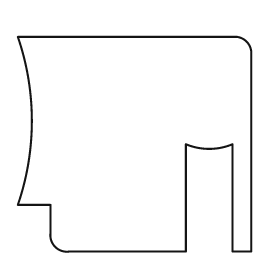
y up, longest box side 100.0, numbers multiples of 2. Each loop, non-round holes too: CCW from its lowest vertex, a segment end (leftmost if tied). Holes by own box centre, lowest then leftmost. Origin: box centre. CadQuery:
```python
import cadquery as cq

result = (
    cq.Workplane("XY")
    .moveTo(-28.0, -46.0)
    .lineTo(22.0, -46.0)
    .lineTo(22.0, 0.0)
    .threePointArc((32.0, -2.0), (42.0, 0.0))
    .lineTo(42.0, -46.0)
    .lineTo(50.0, -46.0)
    .lineTo(50.0, 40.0)
    .threePointArc((48.0, 44.0), (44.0, 46.0))
    .lineTo(-50.0, 46.0)
    .threePointArc((-44.0, 10.0), (-50.0, -26.0))
    .lineTo(-36.0, -26.0)
    .lineTo(-36.0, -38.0)
    .threePointArc((-34.0, -44.0), (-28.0, -46.0))
    .close()
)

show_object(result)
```